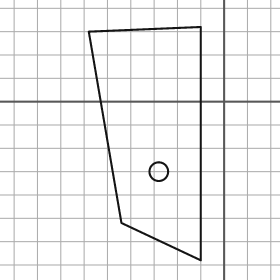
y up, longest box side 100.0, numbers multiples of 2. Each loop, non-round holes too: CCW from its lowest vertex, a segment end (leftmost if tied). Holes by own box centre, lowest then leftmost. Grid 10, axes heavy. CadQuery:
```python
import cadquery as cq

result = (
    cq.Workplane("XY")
    .moveTo(-10.0, -68.0)
    .lineTo(-10.0, 32.0)
    .lineTo(-58.0, 30.0)
    .lineTo(-44.0, -52.0)
    .close()
    .moveTo(-28.0, -30.0)
    .circle(4.0)
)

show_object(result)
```